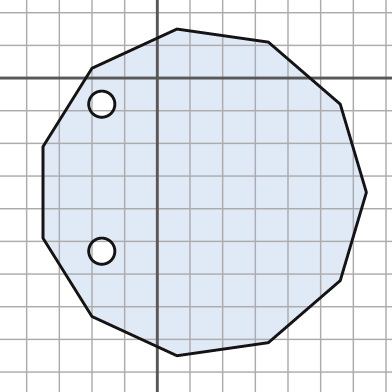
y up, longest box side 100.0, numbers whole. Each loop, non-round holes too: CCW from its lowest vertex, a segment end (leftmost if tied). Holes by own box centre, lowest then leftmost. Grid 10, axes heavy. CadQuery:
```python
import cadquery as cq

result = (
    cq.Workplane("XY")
    .moveTo(6.0, -85.0)
    .lineTo(34.0, -81.0)
    .lineTo(56.0, -62.0)
    .lineTo(64.0, -35.0)
    .lineTo(56.0, -8.0)
    .lineTo(34.0, 11.0)
    .lineTo(6.0, 15.0)
    .lineTo(-20.0, 3.0)
    .lineTo(-35.0, -21.0)
    .lineTo(-35.0, -49.0)
    .lineTo(-20.0, -73.0)
    .close()
    .moveTo(-17.0, -53.0)
    .circle(4.0)
    .moveTo(-17.0, -8.0)
    .circle(4.0)
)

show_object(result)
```